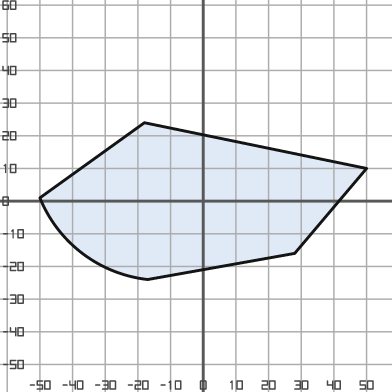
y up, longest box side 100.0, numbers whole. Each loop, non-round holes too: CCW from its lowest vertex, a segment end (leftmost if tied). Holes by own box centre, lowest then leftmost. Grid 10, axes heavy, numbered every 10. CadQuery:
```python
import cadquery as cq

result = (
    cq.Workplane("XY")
    .moveTo(-17.0, -24.0)
    .lineTo(28.0, -16.0)
    .lineTo(50.0, 10.0)
    .lineTo(-18.0, 24.0)
    .lineTo(-50.0, 1.0)
    .threePointArc((-37.0, -16.0), (-17.0, -24.0))
    .close()
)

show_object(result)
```